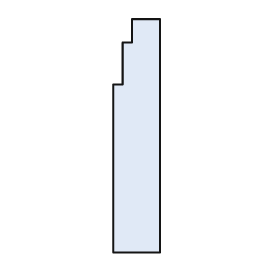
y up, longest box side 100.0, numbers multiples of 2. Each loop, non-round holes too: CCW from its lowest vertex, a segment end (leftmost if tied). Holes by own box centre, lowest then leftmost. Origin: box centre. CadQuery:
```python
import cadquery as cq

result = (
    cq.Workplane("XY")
    .moveTo(-10.0, -50.0)
    .lineTo(10.0, -50.0)
    .lineTo(10.0, 50.0)
    .lineTo(-2.0, 50.0)
    .lineTo(-2.0, 40.0)
    .lineTo(-6.0, 40.0)
    .lineTo(-6.0, 22.0)
    .lineTo(-10.0, 22.0)
    .close()
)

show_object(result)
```